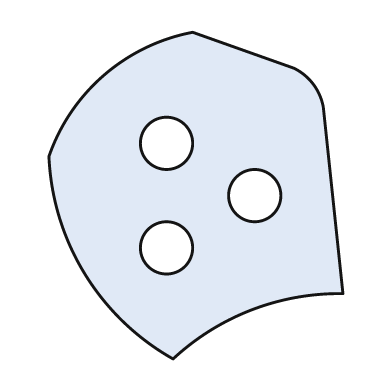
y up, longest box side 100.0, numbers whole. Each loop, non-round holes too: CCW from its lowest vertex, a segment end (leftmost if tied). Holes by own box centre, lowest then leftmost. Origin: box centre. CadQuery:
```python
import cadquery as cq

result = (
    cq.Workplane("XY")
    .moveTo(-7.0, -50.0)
    .threePointArc((17.0, -35.0), (45.0, -30.0))
    .lineTo(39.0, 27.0)
    .threePointArc((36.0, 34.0), (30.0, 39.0))
    .lineTo(-1.0, 50.0)
    .threePointArc((-28.0, 37.0), (-45.0, 12.0))
    .threePointArc((-34.0, -24.0), (-7.0, -50.0))
    .close()
    .moveTo(-9.0, -16.0)
    .circle(8.0)
    .moveTo(18.0, 0.0)
    .circle(8.0)
    .moveTo(-9.0, 16.0)
    .circle(8.0)
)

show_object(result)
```